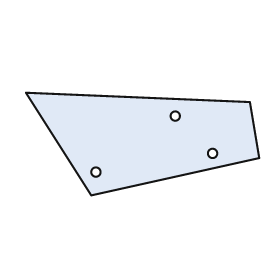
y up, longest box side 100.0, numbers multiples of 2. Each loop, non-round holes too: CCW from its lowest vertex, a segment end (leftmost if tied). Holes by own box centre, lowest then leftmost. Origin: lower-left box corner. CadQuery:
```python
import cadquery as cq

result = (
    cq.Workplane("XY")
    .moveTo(28.0, 0.0)
    .lineTo(100.0, 16.0)
    .lineTo(96.0, 40.0)
    .lineTo(0.0, 44.0)
    .close()
    .moveTo(30.0, 10.0)
    .circle(2.0)
    .moveTo(80.0, 18.0)
    .circle(2.0)
    .moveTo(64.0, 34.0)
    .circle(2.0)
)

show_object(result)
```